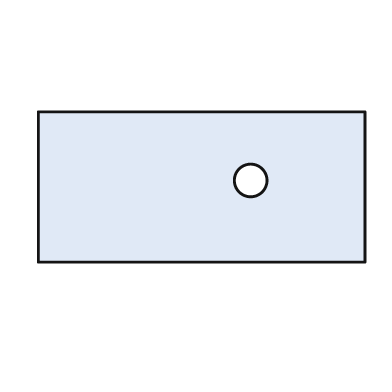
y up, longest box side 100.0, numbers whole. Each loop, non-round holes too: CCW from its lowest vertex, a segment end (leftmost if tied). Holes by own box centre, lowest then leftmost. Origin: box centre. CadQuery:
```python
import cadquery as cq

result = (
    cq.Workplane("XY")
    .moveTo(-50.0, -23.0)
    .lineTo(50.0, -23.0)
    .lineTo(50.0, 23.0)
    .lineTo(-50.0, 23.0)
    .close()
    .moveTo(15.0, 2.0)
    .circle(5.0)
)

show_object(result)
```